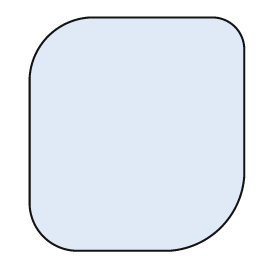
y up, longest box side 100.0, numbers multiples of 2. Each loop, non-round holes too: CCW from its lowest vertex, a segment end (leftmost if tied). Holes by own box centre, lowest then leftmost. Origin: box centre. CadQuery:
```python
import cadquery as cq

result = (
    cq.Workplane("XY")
    .moveTo(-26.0, -50.0)
    .lineTo(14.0, -50.0)
    .threePointArc((36.0, -40.0), (46.0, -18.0))
    .lineTo(46.0, 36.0)
    .threePointArc((42.0, 46.0), (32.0, 50.0))
    .lineTo(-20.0, 50.0)
    .threePointArc((-38.0, 42.0), (-46.0, 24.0))
    .lineTo(-46.0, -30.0)
    .threePointArc((-40.0, -44.0), (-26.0, -50.0))
    .close()
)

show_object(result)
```